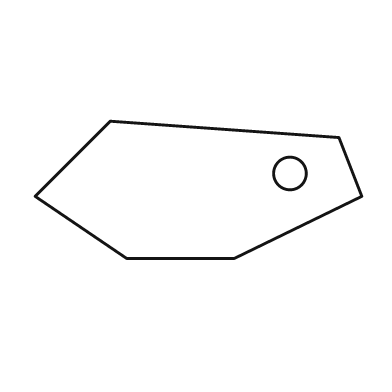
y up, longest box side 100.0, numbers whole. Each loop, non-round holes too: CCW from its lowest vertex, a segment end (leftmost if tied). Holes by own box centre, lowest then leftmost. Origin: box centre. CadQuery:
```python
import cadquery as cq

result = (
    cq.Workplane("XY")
    .moveTo(-22.0, -21.0)
    .lineTo(11.0, -21.0)
    .lineTo(50.0, -2.0)
    .lineTo(43.0, 16.0)
    .lineTo(-27.0, 21.0)
    .lineTo(-50.0, -2.0)
    .close()
    .moveTo(28.0, 5.0)
    .circle(5.0)
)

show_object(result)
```